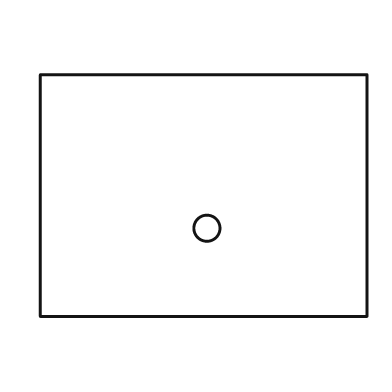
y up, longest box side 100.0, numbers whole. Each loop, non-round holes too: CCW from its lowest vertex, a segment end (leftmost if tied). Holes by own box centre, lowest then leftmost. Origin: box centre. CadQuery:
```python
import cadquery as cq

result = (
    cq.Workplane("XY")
    .moveTo(-50.0, -37.0)
    .lineTo(50.0, -37.0)
    .lineTo(50.0, 37.0)
    .lineTo(-50.0, 37.0)
    .close()
    .moveTo(1.0, -10.0)
    .circle(4.0)
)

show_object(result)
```